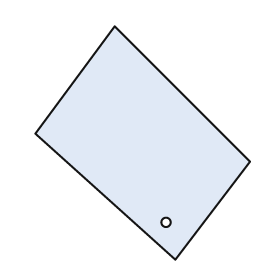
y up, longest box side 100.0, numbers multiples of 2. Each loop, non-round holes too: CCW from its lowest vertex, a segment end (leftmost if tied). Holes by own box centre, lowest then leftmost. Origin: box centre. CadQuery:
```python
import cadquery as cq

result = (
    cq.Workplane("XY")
    .moveTo(14.0, -50.0)
    .lineTo(46.0, -8.0)
    .lineTo(-12.0, 50.0)
    .lineTo(-46.0, 4.0)
    .close()
    .moveTo(10.0, -34.0)
    .circle(2.0)
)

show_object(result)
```